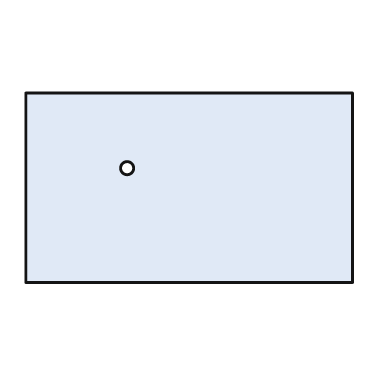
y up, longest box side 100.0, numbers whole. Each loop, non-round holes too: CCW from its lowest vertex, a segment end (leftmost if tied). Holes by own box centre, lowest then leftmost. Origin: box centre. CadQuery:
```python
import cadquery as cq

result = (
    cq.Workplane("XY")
    .moveTo(-50.0, -29.0)
    .lineTo(50.0, -29.0)
    .lineTo(50.0, 29.0)
    .lineTo(-50.0, 29.0)
    .close()
    .moveTo(-19.0, 6.0)
    .circle(2.0)
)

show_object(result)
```